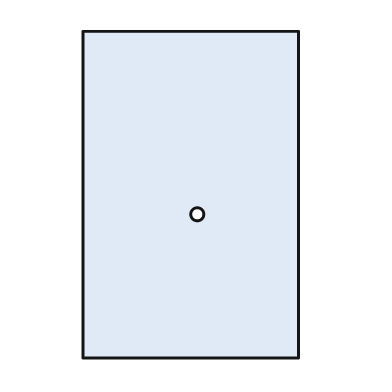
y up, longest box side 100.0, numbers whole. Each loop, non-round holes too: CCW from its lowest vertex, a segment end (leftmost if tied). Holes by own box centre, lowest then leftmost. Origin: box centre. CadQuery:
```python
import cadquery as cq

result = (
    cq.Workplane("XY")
    .moveTo(-33.0, -50.0)
    .lineTo(33.0, -50.0)
    .lineTo(33.0, 50.0)
    .lineTo(-33.0, 50.0)
    .close()
    .moveTo(2.0, -6.0)
    .circle(2.0)
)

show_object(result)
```